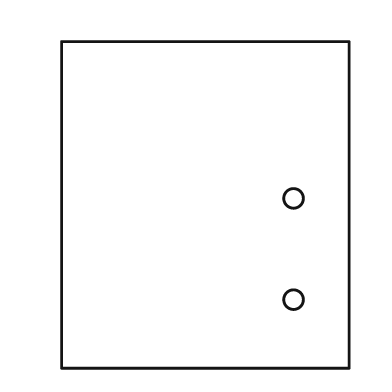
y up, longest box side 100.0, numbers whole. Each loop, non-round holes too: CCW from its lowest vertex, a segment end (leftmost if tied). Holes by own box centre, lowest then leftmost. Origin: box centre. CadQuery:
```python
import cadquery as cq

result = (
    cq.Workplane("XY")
    .moveTo(-44.0, -50.0)
    .lineTo(44.0, -50.0)
    .lineTo(44.0, 50.0)
    .lineTo(-44.0, 50.0)
    .close()
    .moveTo(27.0, -29.0)
    .circle(3.0)
    .moveTo(27.0, 2.0)
    .circle(3.0)
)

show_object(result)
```